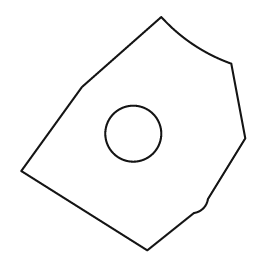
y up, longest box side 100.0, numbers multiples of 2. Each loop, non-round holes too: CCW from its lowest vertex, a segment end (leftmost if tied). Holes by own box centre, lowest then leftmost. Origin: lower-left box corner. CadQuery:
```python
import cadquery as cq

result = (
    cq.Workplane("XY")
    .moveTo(54.0, 0.0)
    .lineTo(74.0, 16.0)
    .threePointArc((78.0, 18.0), (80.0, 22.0))
    .lineTo(96.0, 48.0)
    .lineTo(90.0, 80.0)
    .threePointArc((74.0, 88.0), (60.0, 100.0))
    .lineTo(26.0, 70.0)
    .lineTo(0.0, 34.0)
    .close()
    .moveTo(48.0, 50.0)
    .circle(12.0)
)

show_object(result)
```